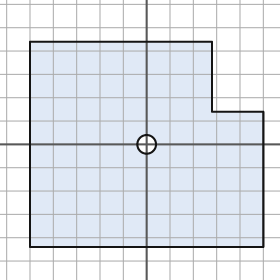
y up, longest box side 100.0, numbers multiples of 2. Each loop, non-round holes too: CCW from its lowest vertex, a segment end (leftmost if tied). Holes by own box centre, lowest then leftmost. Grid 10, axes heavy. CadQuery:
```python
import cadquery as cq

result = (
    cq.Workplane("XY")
    .moveTo(-50.0, -44.0)
    .lineTo(50.0, -44.0)
    .lineTo(50.0, 14.0)
    .lineTo(28.0, 14.0)
    .lineTo(28.0, 44.0)
    .lineTo(-50.0, 44.0)
    .close()
    .moveTo(0.0, 0.0)
    .circle(4.0)
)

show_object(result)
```